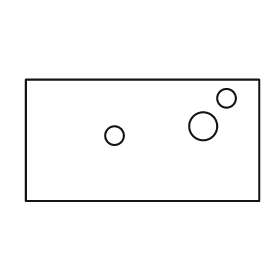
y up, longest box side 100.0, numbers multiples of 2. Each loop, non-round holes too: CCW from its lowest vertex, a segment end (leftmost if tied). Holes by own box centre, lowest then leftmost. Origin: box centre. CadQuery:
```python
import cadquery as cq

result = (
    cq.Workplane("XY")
    .moveTo(-50.0, -26.0)
    .lineTo(50.0, -26.0)
    .lineTo(50.0, 26.0)
    .lineTo(-50.0, 26.0)
    .close()
    .moveTo(-12.0, 2.0)
    .circle(4.0)
    .moveTo(26.0, 6.0)
    .circle(6.0)
    .moveTo(36.0, 18.0)
    .circle(4.0)
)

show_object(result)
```